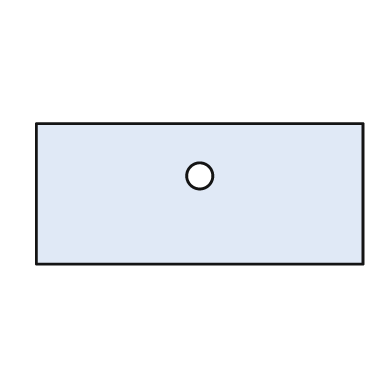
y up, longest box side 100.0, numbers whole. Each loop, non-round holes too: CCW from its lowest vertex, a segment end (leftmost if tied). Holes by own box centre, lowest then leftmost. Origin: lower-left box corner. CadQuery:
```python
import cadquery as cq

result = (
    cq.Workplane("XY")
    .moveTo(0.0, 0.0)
    .lineTo(100.0, 0.0)
    .lineTo(100.0, 43.0)
    .lineTo(0.0, 43.0)
    .close()
    .moveTo(50.0, 27.0)
    .circle(4.0)
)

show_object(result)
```